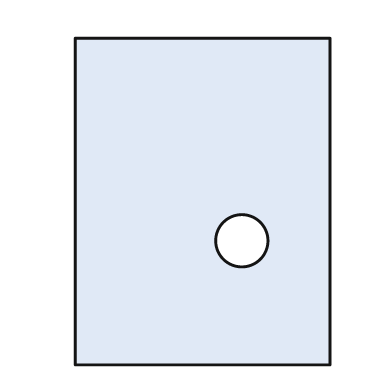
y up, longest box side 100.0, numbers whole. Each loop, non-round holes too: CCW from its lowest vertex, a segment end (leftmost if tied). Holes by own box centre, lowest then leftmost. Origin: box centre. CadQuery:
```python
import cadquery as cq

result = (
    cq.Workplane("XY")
    .moveTo(-39.0, -50.0)
    .lineTo(39.0, -50.0)
    .lineTo(39.0, 50.0)
    .lineTo(-39.0, 50.0)
    .close()
    .moveTo(12.0, -12.0)
    .circle(8.0)
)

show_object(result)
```